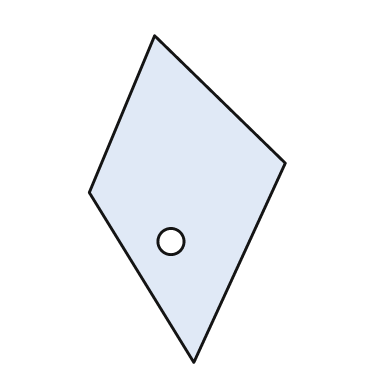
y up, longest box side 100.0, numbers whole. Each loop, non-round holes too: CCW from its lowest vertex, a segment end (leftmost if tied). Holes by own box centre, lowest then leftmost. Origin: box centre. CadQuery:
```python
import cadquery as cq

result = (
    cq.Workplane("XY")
    .moveTo(2.0, -50.0)
    .lineTo(30.0, 11.0)
    .lineTo(-10.0, 50.0)
    .lineTo(-30.0, 2.0)
    .close()
    .moveTo(-5.0, -13.0)
    .circle(4.0)
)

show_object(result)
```